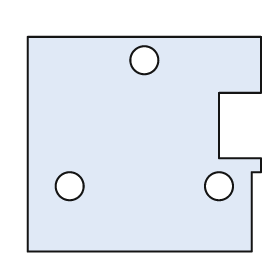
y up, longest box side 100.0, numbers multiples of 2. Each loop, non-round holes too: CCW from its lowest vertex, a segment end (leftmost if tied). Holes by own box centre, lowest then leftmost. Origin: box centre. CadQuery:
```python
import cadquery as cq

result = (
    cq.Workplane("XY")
    .moveTo(-50.0, -46.0)
    .lineTo(46.0, -46.0)
    .lineTo(46.0, -12.0)
    .lineTo(50.0, -12.0)
    .lineTo(50.0, -6.0)
    .lineTo(32.0, -6.0)
    .lineTo(32.0, 22.0)
    .lineTo(50.0, 22.0)
    .lineTo(50.0, 46.0)
    .lineTo(-50.0, 46.0)
    .close()
    .moveTo(-32.0, -18.0)
    .circle(6.0)
    .moveTo(32.0, -18.0)
    .circle(6.0)
    .moveTo(0.0, 36.0)
    .circle(6.0)
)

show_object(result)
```